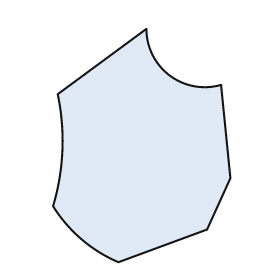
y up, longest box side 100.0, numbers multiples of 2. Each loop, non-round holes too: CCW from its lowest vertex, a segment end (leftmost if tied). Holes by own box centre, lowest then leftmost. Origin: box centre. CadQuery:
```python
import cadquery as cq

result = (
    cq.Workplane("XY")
    .moveTo(-10.0, -50.0)
    .lineTo(28.0, -36.0)
    .lineTo(38.0, -14.0)
    .lineTo(34.0, 26.0)
    .threePointArc((12.0, 30.0), (2.0, 50.0))
    .lineTo(-36.0, 22.0)
    .threePointArc((-34.0, -2.0), (-38.0, -26.0))
    .threePointArc((-26.0, -40.0), (-10.0, -50.0))
    .close()
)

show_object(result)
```